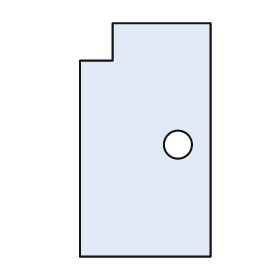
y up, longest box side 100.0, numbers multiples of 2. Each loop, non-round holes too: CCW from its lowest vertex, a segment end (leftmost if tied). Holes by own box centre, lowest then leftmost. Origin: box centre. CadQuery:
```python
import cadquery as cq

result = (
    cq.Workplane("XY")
    .moveTo(-28.0, -50.0)
    .lineTo(28.0, -50.0)
    .lineTo(28.0, 50.0)
    .lineTo(-14.0, 50.0)
    .lineTo(-14.0, 34.0)
    .lineTo(-28.0, 34.0)
    .close()
    .moveTo(14.0, -2.0)
    .circle(6.0)
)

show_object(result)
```